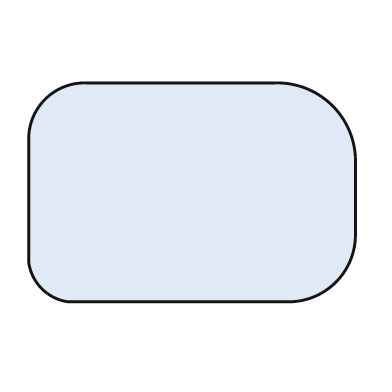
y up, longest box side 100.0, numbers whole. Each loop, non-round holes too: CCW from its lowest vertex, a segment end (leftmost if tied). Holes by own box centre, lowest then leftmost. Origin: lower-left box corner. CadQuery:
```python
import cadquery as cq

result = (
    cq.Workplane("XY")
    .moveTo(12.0, 0.0)
    .lineTo(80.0, 0.0)
    .threePointArc((94.0, 6.0), (100.0, 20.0))
    .lineTo(100.0, 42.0)
    .threePointArc((93.0, 60.0), (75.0, 67.0))
    .lineTo(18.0, 67.0)
    .threePointArc((5.0, 62.0), (0.0, 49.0))
    .lineTo(0.0, 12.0)
    .threePointArc((4.0, 4.0), (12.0, 0.0))
    .close()
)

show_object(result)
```